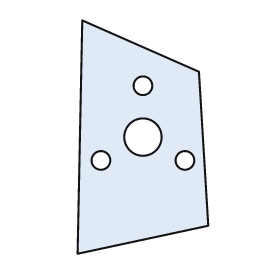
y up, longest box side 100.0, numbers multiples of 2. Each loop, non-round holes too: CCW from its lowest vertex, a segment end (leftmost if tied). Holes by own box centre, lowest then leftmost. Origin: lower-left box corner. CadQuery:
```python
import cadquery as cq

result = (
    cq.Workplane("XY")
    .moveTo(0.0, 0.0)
    .lineTo(56.0, 12.0)
    .lineTo(52.0, 78.0)
    .lineTo(2.0, 100.0)
    .close()
    .moveTo(10.0, 40.0)
    .circle(4.0)
    .moveTo(46.0, 40.0)
    .circle(4.0)
    .moveTo(28.0, 50.0)
    .circle(8.0)
    .moveTo(28.0, 72.0)
    .circle(4.0)
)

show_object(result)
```